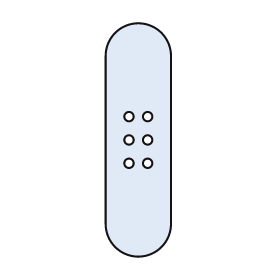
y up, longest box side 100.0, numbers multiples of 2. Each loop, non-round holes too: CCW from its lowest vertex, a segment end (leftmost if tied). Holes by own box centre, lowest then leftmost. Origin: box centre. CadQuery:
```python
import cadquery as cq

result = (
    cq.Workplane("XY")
    .moveTo(-14.0, -36.0)
    .threePointArc((0.0, -50.0), (14.0, -36.0))
    .lineTo(14.0, 36.0)
    .threePointArc((0.0, 50.0), (-14.0, 36.0))
    .close()
    .moveTo(-4.0, -10.0)
    .circle(2.0)
    .moveTo(4.0, -10.0)
    .circle(2.0)
    .moveTo(-4.0, 0.0)
    .circle(2.0)
    .moveTo(4.0, 0.0)
    .circle(2.0)
    .moveTo(-4.0, 10.0)
    .circle(2.0)
    .moveTo(4.0, 10.0)
    .circle(2.0)
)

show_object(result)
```